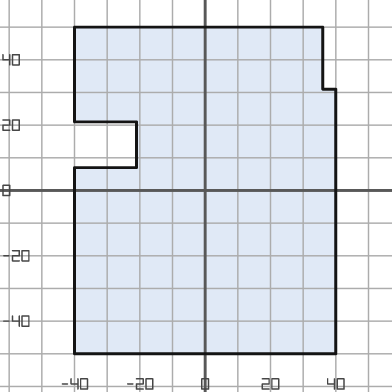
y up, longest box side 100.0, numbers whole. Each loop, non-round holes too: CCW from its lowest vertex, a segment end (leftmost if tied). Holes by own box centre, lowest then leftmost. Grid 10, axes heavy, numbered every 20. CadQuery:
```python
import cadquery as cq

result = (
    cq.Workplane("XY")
    .moveTo(-40.0, -50.0)
    .lineTo(40.0, -50.0)
    .lineTo(40.0, 31.0)
    .lineTo(36.0, 31.0)
    .lineTo(36.0, 50.0)
    .lineTo(-40.0, 50.0)
    .lineTo(-40.0, 21.0)
    .lineTo(-21.0, 21.0)
    .lineTo(-21.0, 7.0)
    .lineTo(-40.0, 7.0)
    .close()
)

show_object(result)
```